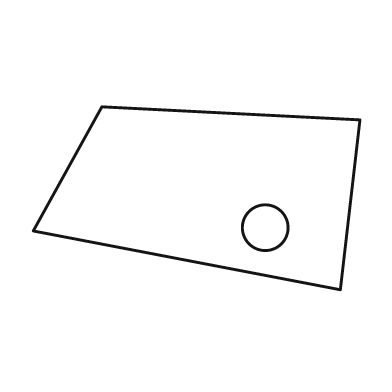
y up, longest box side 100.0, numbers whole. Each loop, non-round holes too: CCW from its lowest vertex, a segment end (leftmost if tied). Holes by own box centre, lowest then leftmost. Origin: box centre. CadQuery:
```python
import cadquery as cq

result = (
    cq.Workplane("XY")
    .moveTo(44.0, -28.0)
    .lineTo(50.0, 24.0)
    .lineTo(-29.0, 28.0)
    .lineTo(-50.0, -10.0)
    .close()
    .moveTo(21.0, -9.0)
    .circle(7.0)
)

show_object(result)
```